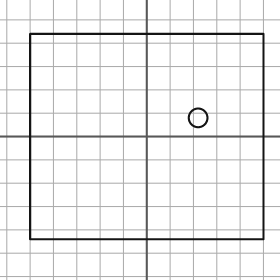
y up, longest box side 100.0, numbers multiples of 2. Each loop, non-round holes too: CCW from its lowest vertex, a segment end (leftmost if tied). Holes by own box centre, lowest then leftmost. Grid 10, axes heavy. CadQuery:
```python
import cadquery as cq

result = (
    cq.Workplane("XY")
    .moveTo(-50.0, -44.0)
    .lineTo(50.0, -44.0)
    .lineTo(50.0, 44.0)
    .lineTo(-50.0, 44.0)
    .close()
    .moveTo(22.0, 8.0)
    .circle(4.0)
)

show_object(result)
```